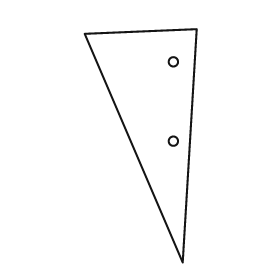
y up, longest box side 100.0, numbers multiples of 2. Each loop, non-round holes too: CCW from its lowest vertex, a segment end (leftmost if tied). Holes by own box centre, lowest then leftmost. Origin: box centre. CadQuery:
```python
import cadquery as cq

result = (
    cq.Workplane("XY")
    .moveTo(18.0, -50.0)
    .lineTo(24.0, 50.0)
    .lineTo(-24.0, 48.0)
    .close()
    .moveTo(14.0, 2.0)
    .circle(2.0)
    .moveTo(14.0, 36.0)
    .circle(2.0)
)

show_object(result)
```